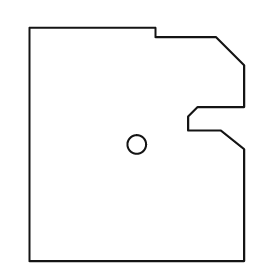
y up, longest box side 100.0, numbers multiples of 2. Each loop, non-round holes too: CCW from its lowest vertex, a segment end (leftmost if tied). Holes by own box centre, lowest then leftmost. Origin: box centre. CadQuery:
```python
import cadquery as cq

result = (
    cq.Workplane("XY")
    .moveTo(-46.0, -50.0)
    .lineTo(46.0, -50.0)
    .lineTo(46.0, -2.0)
    .lineTo(36.0, 6.0)
    .lineTo(22.0, 6.0)
    .lineTo(22.0, 12.0)
    .lineTo(26.0, 16.0)
    .lineTo(46.0, 16.0)
    .lineTo(46.0, 34.0)
    .lineTo(34.0, 46.0)
    .lineTo(8.0, 46.0)
    .lineTo(8.0, 50.0)
    .lineTo(-46.0, 50.0)
    .close()
    .moveTo(0.0, 0.0)
    .circle(4.0)
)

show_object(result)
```